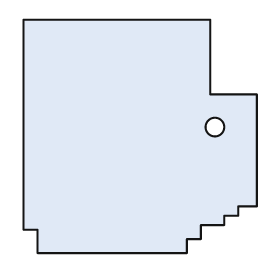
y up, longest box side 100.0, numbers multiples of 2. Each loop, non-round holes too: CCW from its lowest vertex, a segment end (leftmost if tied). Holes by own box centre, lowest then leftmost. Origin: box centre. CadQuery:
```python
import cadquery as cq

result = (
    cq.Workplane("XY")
    .moveTo(-44.0, -50.0)
    .lineTo(20.0, -50.0)
    .lineTo(20.0, -44.0)
    .lineTo(26.0, -44.0)
    .lineTo(26.0, -38.0)
    .lineTo(36.0, -38.0)
    .lineTo(36.0, -34.0)
    .lineTo(42.0, -34.0)
    .lineTo(42.0, -30.0)
    .lineTo(50.0, -30.0)
    .lineTo(50.0, 18.0)
    .lineTo(30.0, 18.0)
    .lineTo(30.0, 50.0)
    .lineTo(-50.0, 50.0)
    .lineTo(-50.0, -40.0)
    .lineTo(-44.0, -40.0)
    .close()
    .moveTo(32.0, 4.0)
    .circle(4.0)
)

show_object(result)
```